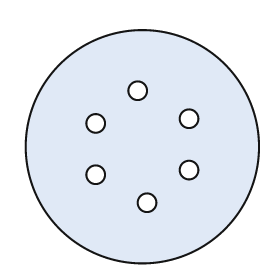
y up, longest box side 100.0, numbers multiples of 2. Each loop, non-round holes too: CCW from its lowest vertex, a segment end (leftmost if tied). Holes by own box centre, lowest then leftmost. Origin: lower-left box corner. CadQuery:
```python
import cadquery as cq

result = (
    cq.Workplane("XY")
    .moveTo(50.0, 50.0)
    .circle(50.0)
    .moveTo(52.0, 26.0)
    .circle(4.0)
    .moveTo(30.0, 38.0)
    .circle(4.0)
    .moveTo(70.0, 40.0)
    .circle(4.0)
    .moveTo(30.0, 60.0)
    .circle(4.0)
    .moveTo(70.0, 62.0)
    .circle(4.0)
    .moveTo(48.0, 74.0)
    .circle(4.0)
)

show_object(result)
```